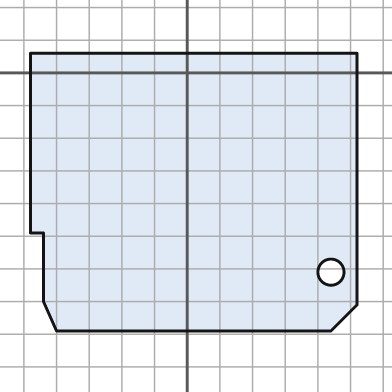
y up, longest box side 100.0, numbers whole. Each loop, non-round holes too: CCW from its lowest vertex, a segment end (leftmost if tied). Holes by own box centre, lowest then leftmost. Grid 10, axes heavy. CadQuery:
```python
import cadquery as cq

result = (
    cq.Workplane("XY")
    .moveTo(-40.0, -79.0)
    .lineTo(44.0, -79.0)
    .lineTo(52.0, -71.0)
    .lineTo(52.0, 6.0)
    .lineTo(-48.0, 6.0)
    .lineTo(-48.0, -49.0)
    .lineTo(-44.0, -49.0)
    .lineTo(-44.0, -70.0)
    .close()
    .moveTo(44.0, -61.0)
    .circle(4.0)
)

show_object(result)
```